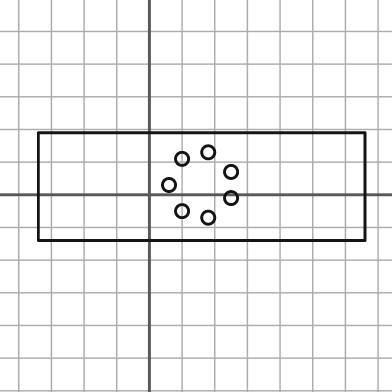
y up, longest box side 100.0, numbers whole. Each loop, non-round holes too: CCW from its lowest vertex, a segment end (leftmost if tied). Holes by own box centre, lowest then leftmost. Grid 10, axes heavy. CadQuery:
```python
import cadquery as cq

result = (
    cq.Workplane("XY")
    .moveTo(-34.0, -14.0)
    .lineTo(66.0, -14.0)
    .lineTo(66.0, 19.0)
    .lineTo(-34.0, 19.0)
    .close()
    .moveTo(18.0, -7.0)
    .circle(2.0)
    .moveTo(10.0, -5.0)
    .circle(2.0)
    .moveTo(25.0, -1.0)
    .circle(2.0)
    .moveTo(6.0, 3.0)
    .circle(2.0)
    .moveTo(25.0, 7.0)
    .circle(2.0)
    .moveTo(10.0, 11.0)
    .circle(2.0)
    .moveTo(18.0, 13.0)
    .circle(2.0)
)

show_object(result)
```